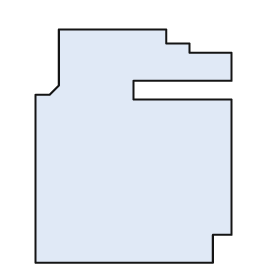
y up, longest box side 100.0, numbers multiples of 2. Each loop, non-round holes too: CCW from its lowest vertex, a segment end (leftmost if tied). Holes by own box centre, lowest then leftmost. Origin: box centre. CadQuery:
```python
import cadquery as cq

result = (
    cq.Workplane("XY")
    .moveTo(-42.0, -50.0)
    .lineTo(34.0, -50.0)
    .lineTo(34.0, -38.0)
    .lineTo(42.0, -38.0)
    .lineTo(42.0, 20.0)
    .lineTo(0.0, 20.0)
    .lineTo(0.0, 28.0)
    .lineTo(42.0, 28.0)
    .lineTo(42.0, 40.0)
    .lineTo(24.0, 40.0)
    .lineTo(24.0, 44.0)
    .lineTo(14.0, 44.0)
    .lineTo(14.0, 50.0)
    .lineTo(-32.0, 50.0)
    .lineTo(-32.0, 26.0)
    .lineTo(-36.0, 22.0)
    .lineTo(-42.0, 22.0)
    .close()
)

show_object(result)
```